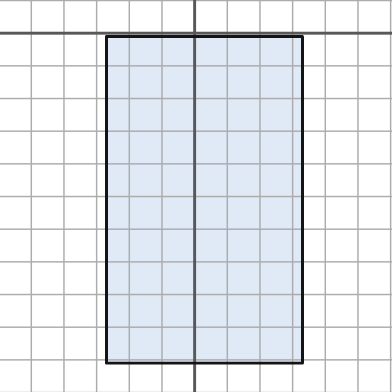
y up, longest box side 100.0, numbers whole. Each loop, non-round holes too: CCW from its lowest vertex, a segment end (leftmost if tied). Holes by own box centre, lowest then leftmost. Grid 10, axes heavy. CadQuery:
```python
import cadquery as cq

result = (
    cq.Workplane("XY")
    .moveTo(-27.0, -101.0)
    .lineTo(33.0, -101.0)
    .lineTo(33.0, -1.0)
    .lineTo(-27.0, -1.0)
    .close()
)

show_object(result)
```